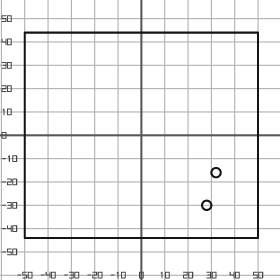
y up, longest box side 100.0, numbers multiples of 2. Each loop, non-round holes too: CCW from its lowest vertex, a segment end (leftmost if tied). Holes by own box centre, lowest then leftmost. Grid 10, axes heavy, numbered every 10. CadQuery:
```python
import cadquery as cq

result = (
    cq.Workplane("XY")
    .moveTo(-50.0, -44.0)
    .lineTo(50.0, -44.0)
    .lineTo(50.0, 44.0)
    .lineTo(-50.0, 44.0)
    .close()
    .moveTo(28.0, -30.0)
    .circle(2.0)
    .moveTo(32.0, -16.0)
    .circle(2.0)
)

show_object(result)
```